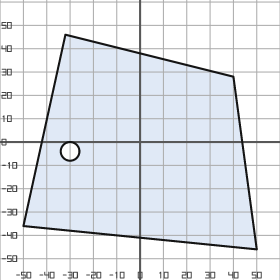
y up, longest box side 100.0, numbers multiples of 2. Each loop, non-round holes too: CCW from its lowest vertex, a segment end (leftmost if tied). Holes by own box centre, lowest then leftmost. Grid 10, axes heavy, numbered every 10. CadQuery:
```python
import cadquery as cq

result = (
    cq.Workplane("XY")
    .moveTo(50.0, -46.0)
    .lineTo(40.0, 28.0)
    .lineTo(-32.0, 46.0)
    .lineTo(-50.0, -36.0)
    .close()
    .moveTo(-30.0, -4.0)
    .circle(4.0)
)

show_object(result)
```